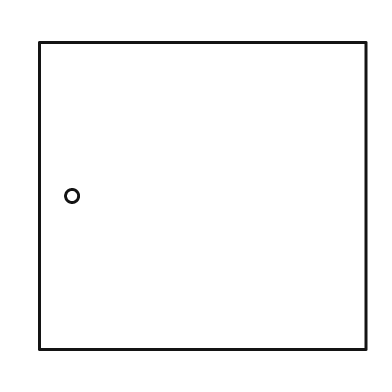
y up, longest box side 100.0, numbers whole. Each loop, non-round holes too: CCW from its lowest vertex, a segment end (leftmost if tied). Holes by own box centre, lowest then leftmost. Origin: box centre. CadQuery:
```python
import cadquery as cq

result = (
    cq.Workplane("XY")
    .moveTo(-50.0, -47.0)
    .lineTo(50.0, -47.0)
    .lineTo(50.0, 47.0)
    .lineTo(-50.0, 47.0)
    .close()
    .moveTo(-40.0, 0.0)
    .circle(2.0)
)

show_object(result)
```